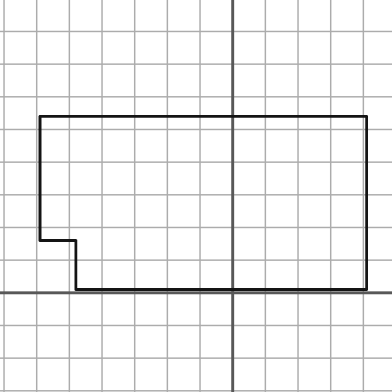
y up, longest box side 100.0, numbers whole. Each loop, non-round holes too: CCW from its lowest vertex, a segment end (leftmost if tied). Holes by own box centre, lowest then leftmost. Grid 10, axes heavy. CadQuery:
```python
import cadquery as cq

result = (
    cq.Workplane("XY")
    .moveTo(-48.0, 1.0)
    .lineTo(41.0, 1.0)
    .lineTo(41.0, 54.0)
    .lineTo(-59.0, 54.0)
    .lineTo(-59.0, 16.0)
    .lineTo(-48.0, 16.0)
    .close()
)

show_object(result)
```